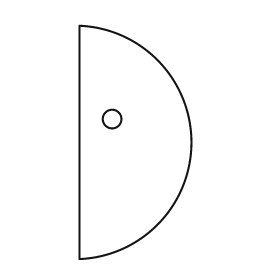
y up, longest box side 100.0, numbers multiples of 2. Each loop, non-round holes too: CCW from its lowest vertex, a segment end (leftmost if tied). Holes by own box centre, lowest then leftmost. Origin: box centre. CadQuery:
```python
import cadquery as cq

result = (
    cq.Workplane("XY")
    .moveTo(-24.0, -50.0)
    .threePointArc((24.0, 0.0), (-24.0, 50.0))
    .close()
    .moveTo(-10.0, 10.0)
    .circle(4.0)
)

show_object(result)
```